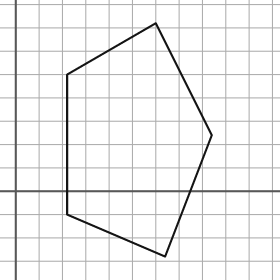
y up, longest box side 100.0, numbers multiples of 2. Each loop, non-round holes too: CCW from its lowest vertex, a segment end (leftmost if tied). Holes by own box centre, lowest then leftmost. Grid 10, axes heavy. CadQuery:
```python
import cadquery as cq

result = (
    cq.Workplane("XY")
    .moveTo(64.0, -28.0)
    .lineTo(84.0, 24.0)
    .lineTo(60.0, 72.0)
    .lineTo(22.0, 50.0)
    .lineTo(22.0, -10.0)
    .close()
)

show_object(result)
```